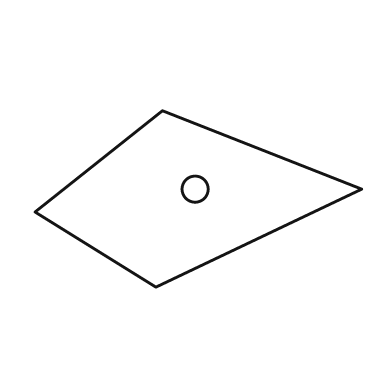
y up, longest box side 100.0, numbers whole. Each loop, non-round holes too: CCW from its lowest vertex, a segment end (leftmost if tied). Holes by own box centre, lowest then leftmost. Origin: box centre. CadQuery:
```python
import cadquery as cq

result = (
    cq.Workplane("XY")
    .moveTo(-13.0, -27.0)
    .lineTo(50.0, 3.0)
    .lineTo(-11.0, 27.0)
    .lineTo(-50.0, -4.0)
    .close()
    .moveTo(-1.0, 3.0)
    .circle(4.0)
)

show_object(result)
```